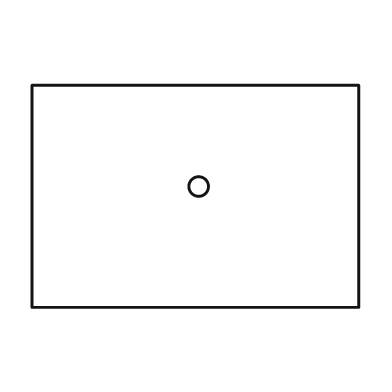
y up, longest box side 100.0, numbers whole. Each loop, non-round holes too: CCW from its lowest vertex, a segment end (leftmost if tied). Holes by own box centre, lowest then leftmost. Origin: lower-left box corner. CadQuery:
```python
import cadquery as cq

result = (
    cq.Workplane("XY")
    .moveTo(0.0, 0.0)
    .lineTo(100.0, 0.0)
    .lineTo(100.0, 68.0)
    .lineTo(0.0, 68.0)
    .close()
    .moveTo(51.0, 37.0)
    .circle(3.0)
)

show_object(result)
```